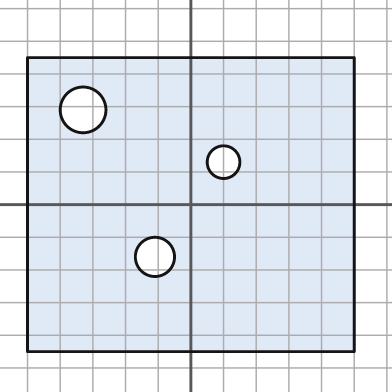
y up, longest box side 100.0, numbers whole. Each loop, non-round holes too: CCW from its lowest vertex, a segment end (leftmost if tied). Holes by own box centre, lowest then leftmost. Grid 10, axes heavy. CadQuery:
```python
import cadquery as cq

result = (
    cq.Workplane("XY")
    .moveTo(-50.0, -45.0)
    .lineTo(50.0, -45.0)
    .lineTo(50.0, 45.0)
    .lineTo(-50.0, 45.0)
    .close()
    .moveTo(-11.0, -16.0)
    .circle(6.0)
    .moveTo(10.0, 13.0)
    .circle(5.0)
    .moveTo(-33.0, 29.0)
    .circle(7.0)
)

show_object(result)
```